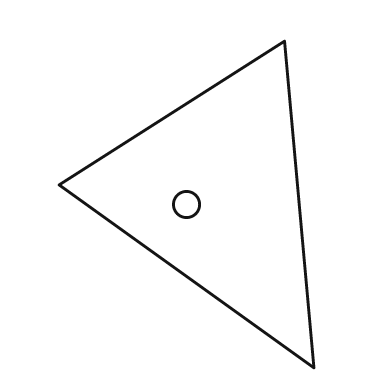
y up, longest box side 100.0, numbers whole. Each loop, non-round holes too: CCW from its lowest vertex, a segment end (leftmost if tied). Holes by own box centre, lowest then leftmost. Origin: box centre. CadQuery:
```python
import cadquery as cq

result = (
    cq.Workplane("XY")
    .moveTo(39.0, -50.0)
    .lineTo(30.0, 50.0)
    .lineTo(-39.0, 6.0)
    .close()
    .moveTo(0.0, 0.0)
    .circle(4.0)
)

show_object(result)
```